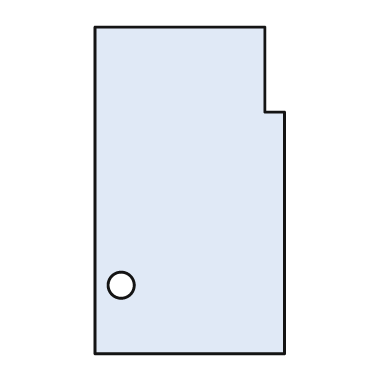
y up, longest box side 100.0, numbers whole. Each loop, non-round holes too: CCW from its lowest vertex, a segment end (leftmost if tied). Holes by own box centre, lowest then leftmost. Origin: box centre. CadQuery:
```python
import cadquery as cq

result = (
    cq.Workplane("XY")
    .moveTo(-29.0, -50.0)
    .lineTo(29.0, -50.0)
    .lineTo(29.0, 24.0)
    .lineTo(23.0, 24.0)
    .lineTo(23.0, 50.0)
    .lineTo(-29.0, 50.0)
    .close()
    .moveTo(-21.0, -29.0)
    .circle(4.0)
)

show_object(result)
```